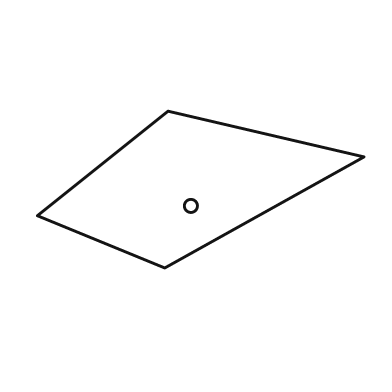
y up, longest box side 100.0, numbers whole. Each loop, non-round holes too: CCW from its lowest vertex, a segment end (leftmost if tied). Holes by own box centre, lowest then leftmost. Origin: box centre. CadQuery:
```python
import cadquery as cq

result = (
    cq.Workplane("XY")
    .moveTo(-11.0, -24.0)
    .lineTo(50.0, 10.0)
    .lineTo(-10.0, 24.0)
    .lineTo(-50.0, -8.0)
    .close()
    .moveTo(-3.0, -5.0)
    .circle(2.0)
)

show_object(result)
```